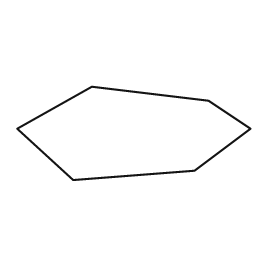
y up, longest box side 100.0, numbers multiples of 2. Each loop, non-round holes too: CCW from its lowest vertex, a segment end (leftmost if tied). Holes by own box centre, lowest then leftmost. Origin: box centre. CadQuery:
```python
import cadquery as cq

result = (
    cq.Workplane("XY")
    .moveTo(-26.0, -20.0)
    .lineTo(26.0, -16.0)
    .lineTo(50.0, 2.0)
    .lineTo(32.0, 14.0)
    .lineTo(-18.0, 20.0)
    .lineTo(-50.0, 2.0)
    .close()
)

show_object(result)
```